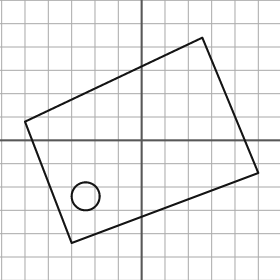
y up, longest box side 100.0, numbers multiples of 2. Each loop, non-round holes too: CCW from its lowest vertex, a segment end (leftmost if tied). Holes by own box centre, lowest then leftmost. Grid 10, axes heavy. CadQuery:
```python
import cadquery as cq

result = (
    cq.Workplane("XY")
    .moveTo(-30.0, -44.0)
    .lineTo(50.0, -14.0)
    .lineTo(26.0, 44.0)
    .lineTo(-50.0, 8.0)
    .close()
    .moveTo(-24.0, -24.0)
    .circle(6.0)
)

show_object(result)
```